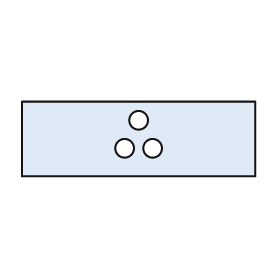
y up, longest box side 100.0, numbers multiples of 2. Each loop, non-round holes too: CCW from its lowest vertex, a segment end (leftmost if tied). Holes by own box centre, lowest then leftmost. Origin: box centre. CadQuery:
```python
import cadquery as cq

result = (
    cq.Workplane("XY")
    .moveTo(-50.0, -16.0)
    .lineTo(50.0, -16.0)
    .lineTo(50.0, 16.0)
    .lineTo(-50.0, 16.0)
    .close()
    .moveTo(-6.0, -4.0)
    .circle(4.0)
    .moveTo(6.0, -4.0)
    .circle(4.0)
    .moveTo(0.0, 8.0)
    .circle(4.0)
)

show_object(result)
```